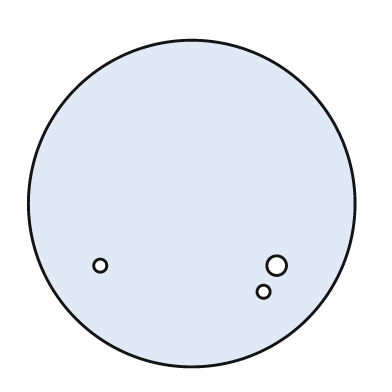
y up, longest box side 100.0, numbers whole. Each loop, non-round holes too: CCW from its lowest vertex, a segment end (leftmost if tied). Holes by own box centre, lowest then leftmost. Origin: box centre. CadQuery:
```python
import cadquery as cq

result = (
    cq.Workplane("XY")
    .moveTo(0.0, 0.0)
    .circle(50.0)
    .moveTo(22.0, -27.0)
    .circle(2.0)
    .moveTo(-28.0, -19.0)
    .circle(2.0)
    .moveTo(26.0, -19.0)
    .circle(3.0)
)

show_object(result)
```